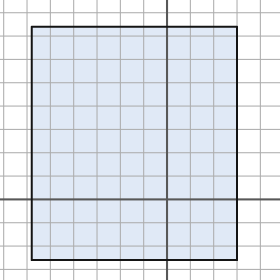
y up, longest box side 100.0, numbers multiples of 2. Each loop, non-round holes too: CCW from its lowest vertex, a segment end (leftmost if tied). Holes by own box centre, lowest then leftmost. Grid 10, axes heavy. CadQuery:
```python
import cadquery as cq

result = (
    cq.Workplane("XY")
    .moveTo(-58.0, -26.0)
    .lineTo(30.0, -26.0)
    .lineTo(30.0, 74.0)
    .lineTo(-58.0, 74.0)
    .close()
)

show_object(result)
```